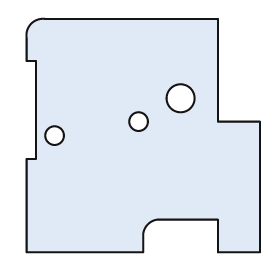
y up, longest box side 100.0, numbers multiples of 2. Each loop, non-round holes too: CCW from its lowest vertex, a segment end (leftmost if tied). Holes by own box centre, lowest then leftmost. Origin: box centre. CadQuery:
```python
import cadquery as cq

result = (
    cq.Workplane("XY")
    .moveTo(-50.0, -50.0)
    .lineTo(0.0, -50.0)
    .lineTo(0.0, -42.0)
    .threePointArc((2.0, -38.0), (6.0, -36.0))
    .lineTo(32.0, -36.0)
    .lineTo(32.0, -50.0)
    .lineTo(50.0, -50.0)
    .lineTo(50.0, 6.0)
    .lineTo(32.0, 6.0)
    .lineTo(32.0, 50.0)
    .lineTo(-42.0, 50.0)
    .threePointArc((-48.0, 48.0), (-50.0, 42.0))
    .lineTo(-50.0, 32.0)
    .lineTo(-46.0, 32.0)
    .lineTo(-46.0, -10.0)
    .lineTo(-50.0, -10.0)
    .close()
    .moveTo(-38.0, 0.0)
    .circle(4.0)
    .moveTo(-2.0, 6.0)
    .circle(4.0)
    .moveTo(16.0, 16.0)
    .circle(6.0)
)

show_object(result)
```